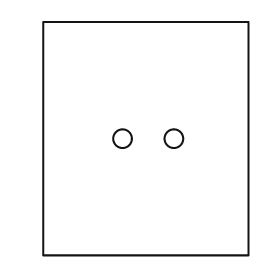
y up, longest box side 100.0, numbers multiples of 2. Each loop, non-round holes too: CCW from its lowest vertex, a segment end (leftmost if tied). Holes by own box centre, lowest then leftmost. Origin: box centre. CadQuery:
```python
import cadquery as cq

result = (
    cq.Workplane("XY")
    .moveTo(-44.0, -50.0)
    .lineTo(44.0, -50.0)
    .lineTo(44.0, 50.0)
    .lineTo(-44.0, 50.0)
    .close()
    .moveTo(-10.0, 0.0)
    .circle(4.0)
    .moveTo(12.0, 0.0)
    .circle(4.0)
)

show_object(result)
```